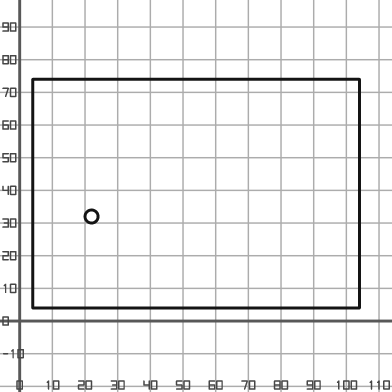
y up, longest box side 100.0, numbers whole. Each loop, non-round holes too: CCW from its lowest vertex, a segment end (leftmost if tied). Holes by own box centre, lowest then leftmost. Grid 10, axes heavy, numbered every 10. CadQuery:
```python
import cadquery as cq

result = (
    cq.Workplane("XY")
    .moveTo(4.0, 4.0)
    .lineTo(104.0, 4.0)
    .lineTo(104.0, 74.0)
    .lineTo(4.0, 74.0)
    .close()
    .moveTo(22.0, 32.0)
    .circle(2.0)
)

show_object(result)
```